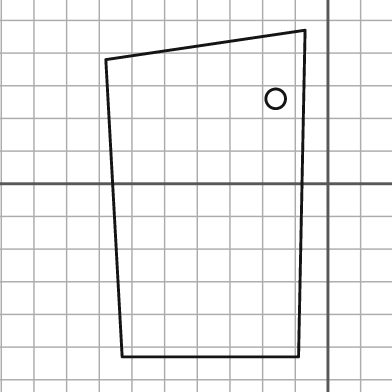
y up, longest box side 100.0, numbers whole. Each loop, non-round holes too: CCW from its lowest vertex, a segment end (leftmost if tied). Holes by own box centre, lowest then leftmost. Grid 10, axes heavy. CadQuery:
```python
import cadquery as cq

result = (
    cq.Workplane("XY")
    .moveTo(-63.0, -53.0)
    .lineTo(-9.0, -53.0)
    .lineTo(-7.0, 47.0)
    .lineTo(-68.0, 38.0)
    .close()
    .moveTo(-16.0, 26.0)
    .circle(3.0)
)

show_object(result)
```